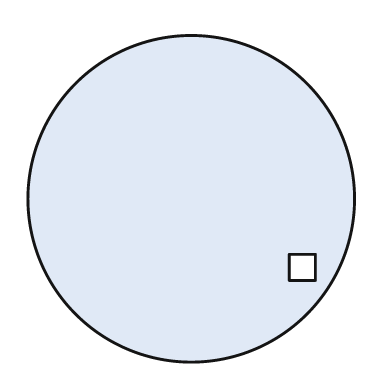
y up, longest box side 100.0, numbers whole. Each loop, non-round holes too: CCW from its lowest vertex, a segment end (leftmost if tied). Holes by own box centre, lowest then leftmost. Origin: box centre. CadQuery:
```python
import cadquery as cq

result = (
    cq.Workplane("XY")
    .moveTo(0.0, 0.0)
    .circle(50.0)
    .moveTo(30.0, -25.0)
    .lineTo(38.0, -25.0)
    .lineTo(38.0, -17.0)
    .lineTo(30.0, -17.0)
    .close()
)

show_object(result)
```